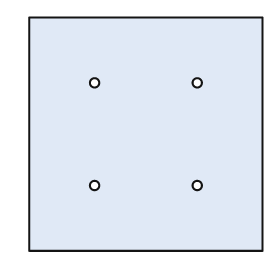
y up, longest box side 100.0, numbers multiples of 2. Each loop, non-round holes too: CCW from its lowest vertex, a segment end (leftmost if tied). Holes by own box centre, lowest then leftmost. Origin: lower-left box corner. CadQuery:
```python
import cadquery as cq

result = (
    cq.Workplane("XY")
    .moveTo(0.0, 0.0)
    .lineTo(100.0, 0.0)
    .lineTo(100.0, 100.0)
    .lineTo(0.0, 100.0)
    .close()
    .moveTo(28.0, 28.0)
    .circle(2.0)
    .moveTo(72.0, 28.0)
    .circle(2.0)
    .moveTo(28.0, 72.0)
    .circle(2.0)
    .moveTo(72.0, 72.0)
    .circle(2.0)
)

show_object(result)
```